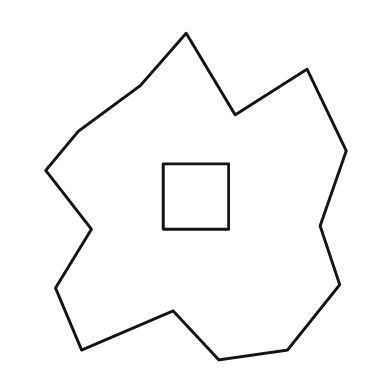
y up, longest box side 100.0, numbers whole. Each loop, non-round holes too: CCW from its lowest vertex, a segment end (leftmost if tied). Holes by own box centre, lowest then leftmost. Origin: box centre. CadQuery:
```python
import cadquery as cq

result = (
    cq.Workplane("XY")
    .moveTo(7.0, -50.0)
    .lineTo(28.0, -47.0)
    .lineTo(44.0, -27.0)
    .lineTo(38.0, -9.0)
    .lineTo(46.0, 14.0)
    .lineTo(34.0, 39.0)
    .lineTo(12.0, 25.0)
    .lineTo(-3.0, 50.0)
    .lineTo(-17.0, 34.0)
    .lineTo(-36.0, 20.0)
    .lineTo(-46.0, 8.0)
    .lineTo(-32.0, -10.0)
    .lineTo(-43.0, -28.0)
    .lineTo(-35.0, -47.0)
    .lineTo(-7.0, -35.0)
    .close()
    .moveTo(-10.0, -10.0)
    .lineTo(10.0, -10.0)
    .lineTo(10.0, 10.0)
    .lineTo(-10.0, 10.0)
    .close()
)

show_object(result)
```